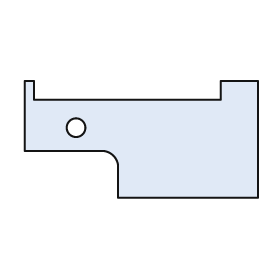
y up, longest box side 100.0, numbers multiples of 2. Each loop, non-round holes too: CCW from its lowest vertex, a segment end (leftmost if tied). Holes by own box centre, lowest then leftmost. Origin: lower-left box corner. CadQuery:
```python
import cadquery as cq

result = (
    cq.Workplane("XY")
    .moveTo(40.0, 0.0)
    .lineTo(100.0, 0.0)
    .lineTo(100.0, 50.0)
    .lineTo(84.0, 50.0)
    .lineTo(84.0, 42.0)
    .lineTo(4.0, 42.0)
    .lineTo(4.0, 50.0)
    .lineTo(0.0, 50.0)
    .lineTo(0.0, 20.0)
    .lineTo(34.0, 20.0)
    .threePointArc((38.0, 18.0), (40.0, 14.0))
    .close()
    .moveTo(22.0, 30.0)
    .circle(4.0)
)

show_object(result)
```